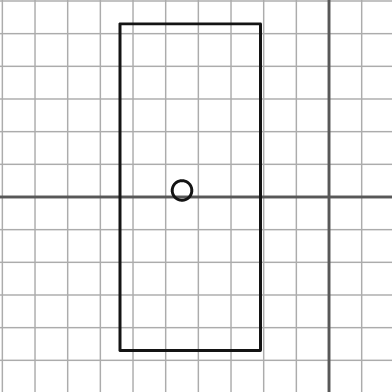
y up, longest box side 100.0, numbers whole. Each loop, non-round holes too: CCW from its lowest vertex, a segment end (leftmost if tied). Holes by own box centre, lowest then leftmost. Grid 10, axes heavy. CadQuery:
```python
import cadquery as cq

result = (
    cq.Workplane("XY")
    .moveTo(-64.0, -47.0)
    .lineTo(-21.0, -47.0)
    .lineTo(-21.0, 53.0)
    .lineTo(-64.0, 53.0)
    .close()
    .moveTo(-45.0, 2.0)
    .circle(3.0)
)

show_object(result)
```